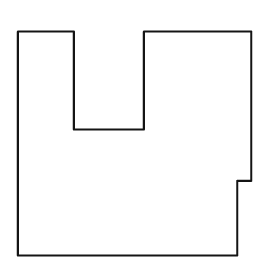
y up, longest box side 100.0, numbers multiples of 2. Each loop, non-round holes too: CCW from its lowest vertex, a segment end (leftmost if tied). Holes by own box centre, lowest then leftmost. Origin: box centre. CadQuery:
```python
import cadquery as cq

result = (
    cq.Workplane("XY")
    .moveTo(-50.0, -48.0)
    .lineTo(44.0, -48.0)
    .lineTo(44.0, -16.0)
    .lineTo(50.0, -16.0)
    .lineTo(50.0, 48.0)
    .lineTo(4.0, 48.0)
    .lineTo(4.0, 6.0)
    .lineTo(-26.0, 6.0)
    .lineTo(-26.0, 48.0)
    .lineTo(-50.0, 48.0)
    .close()
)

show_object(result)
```